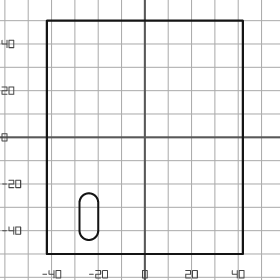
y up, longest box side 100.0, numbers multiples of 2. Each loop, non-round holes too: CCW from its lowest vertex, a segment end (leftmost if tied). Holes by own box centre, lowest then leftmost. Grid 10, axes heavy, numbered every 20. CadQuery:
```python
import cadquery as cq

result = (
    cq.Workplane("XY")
    .moveTo(-42.0, -50.0)
    .lineTo(42.0, -50.0)
    .lineTo(42.0, 50.0)
    .lineTo(-42.0, 50.0)
    .close()
    .moveTo(-28.0, -40.0)
    .threePointArc((-24.0, -44.0), (-20.0, -40.0))
    .lineTo(-20.0, -28.0)
    .threePointArc((-24.0, -24.0), (-28.0, -28.0))
    .close()
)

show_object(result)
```